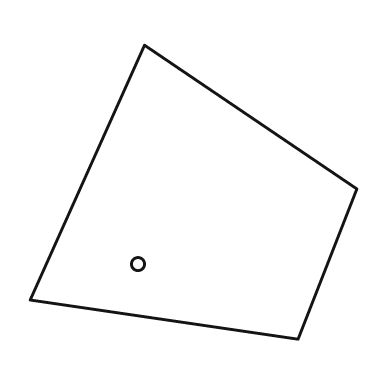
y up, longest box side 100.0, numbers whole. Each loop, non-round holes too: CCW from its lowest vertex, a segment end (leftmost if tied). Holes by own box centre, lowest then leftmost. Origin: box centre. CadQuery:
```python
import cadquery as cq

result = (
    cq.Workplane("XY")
    .moveTo(32.0, -45.0)
    .lineTo(50.0, 1.0)
    .lineTo(-15.0, 45.0)
    .lineTo(-50.0, -33.0)
    .close()
    .moveTo(-17.0, -22.0)
    .circle(2.0)
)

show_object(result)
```